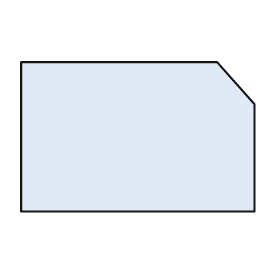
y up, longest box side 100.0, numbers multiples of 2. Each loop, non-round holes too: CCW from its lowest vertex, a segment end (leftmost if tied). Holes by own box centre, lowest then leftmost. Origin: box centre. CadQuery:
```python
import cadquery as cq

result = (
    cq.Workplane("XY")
    .moveTo(-50.0, -32.0)
    .lineTo(50.0, -32.0)
    .lineTo(50.0, 14.0)
    .lineTo(34.0, 32.0)
    .lineTo(-50.0, 32.0)
    .close()
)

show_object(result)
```